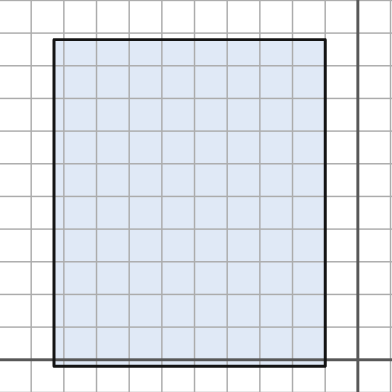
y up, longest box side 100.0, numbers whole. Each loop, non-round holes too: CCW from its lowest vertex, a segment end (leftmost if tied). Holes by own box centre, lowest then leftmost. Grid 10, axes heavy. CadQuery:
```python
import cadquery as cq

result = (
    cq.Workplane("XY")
    .moveTo(-93.0, -2.0)
    .lineTo(-10.0, -2.0)
    .lineTo(-10.0, 98.0)
    .lineTo(-93.0, 98.0)
    .close()
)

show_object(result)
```